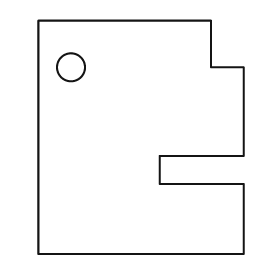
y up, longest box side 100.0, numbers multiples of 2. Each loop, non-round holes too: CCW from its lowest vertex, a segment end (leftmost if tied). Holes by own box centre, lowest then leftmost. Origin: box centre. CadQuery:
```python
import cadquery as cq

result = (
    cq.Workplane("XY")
    .moveTo(-44.0, -50.0)
    .lineTo(44.0, -50.0)
    .lineTo(44.0, -20.0)
    .lineTo(8.0, -20.0)
    .lineTo(8.0, -8.0)
    .lineTo(44.0, -8.0)
    .lineTo(44.0, 30.0)
    .lineTo(30.0, 30.0)
    .lineTo(30.0, 50.0)
    .lineTo(-44.0, 50.0)
    .close()
    .moveTo(-30.0, 30.0)
    .circle(6.0)
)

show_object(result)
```